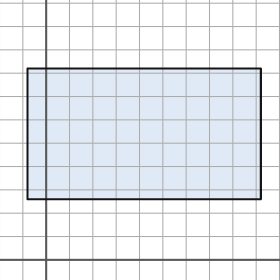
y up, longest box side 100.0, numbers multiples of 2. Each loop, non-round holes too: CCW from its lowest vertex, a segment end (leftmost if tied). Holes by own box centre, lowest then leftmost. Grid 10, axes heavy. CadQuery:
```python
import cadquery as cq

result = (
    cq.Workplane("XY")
    .moveTo(-8.0, 26.0)
    .lineTo(92.0, 26.0)
    .lineTo(92.0, 82.0)
    .lineTo(-8.0, 82.0)
    .close()
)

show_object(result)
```